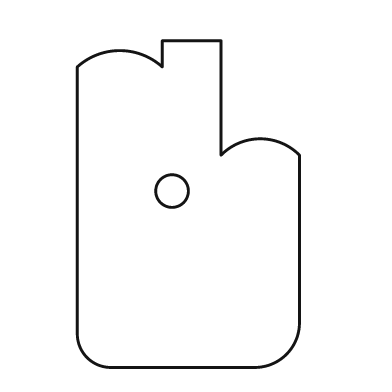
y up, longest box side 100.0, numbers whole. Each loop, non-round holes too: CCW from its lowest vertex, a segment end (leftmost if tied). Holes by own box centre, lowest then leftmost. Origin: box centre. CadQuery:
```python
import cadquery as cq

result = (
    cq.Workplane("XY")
    .moveTo(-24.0, -50.0)
    .lineTo(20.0, -50.0)
    .threePointArc((30.0, -46.0), (34.0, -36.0))
    .lineTo(34.0, 15.0)
    .threePointArc((22.0, 20.0), (10.0, 15.0))
    .lineTo(10.0, 50.0)
    .lineTo(-8.0, 50.0)
    .lineTo(-8.0, 42.0)
    .threePointArc((-21.0, 47.0), (-34.0, 42.0))
    .lineTo(-34.0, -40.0)
    .threePointArc((-31.0, -47.0), (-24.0, -50.0))
    .close()
    .moveTo(-5.0, 4.0)
    .circle(5.0)
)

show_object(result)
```